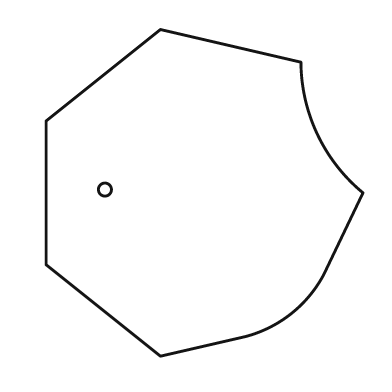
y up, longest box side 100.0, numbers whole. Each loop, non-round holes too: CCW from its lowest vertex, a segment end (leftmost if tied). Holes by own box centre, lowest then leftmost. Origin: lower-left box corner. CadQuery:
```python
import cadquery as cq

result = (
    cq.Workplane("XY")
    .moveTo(35.0, 0.0)
    .lineTo(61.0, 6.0)
    .threePointArc((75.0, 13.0), (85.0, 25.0))
    .lineTo(97.0, 50.0)
    .threePointArc((83.0, 68.0), (78.0, 90.0))
    .lineTo(35.0, 100.0)
    .lineTo(0.0, 72.0)
    .lineTo(0.0, 28.0)
    .close()
    .moveTo(18.0, 51.0)
    .circle(2.0)
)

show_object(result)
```